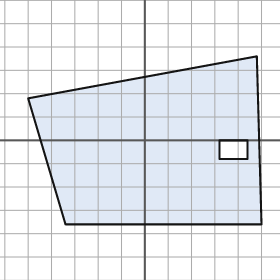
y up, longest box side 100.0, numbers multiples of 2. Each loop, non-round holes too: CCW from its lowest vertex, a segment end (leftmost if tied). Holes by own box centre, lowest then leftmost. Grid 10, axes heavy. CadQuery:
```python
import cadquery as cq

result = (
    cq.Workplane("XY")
    .moveTo(-34.0, -36.0)
    .lineTo(50.0, -36.0)
    .lineTo(48.0, 36.0)
    .lineTo(-50.0, 18.0)
    .close()
    .moveTo(32.0, -8.0)
    .lineTo(44.0, -8.0)
    .lineTo(44.0, 0.0)
    .lineTo(32.0, 0.0)
    .close()
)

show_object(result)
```